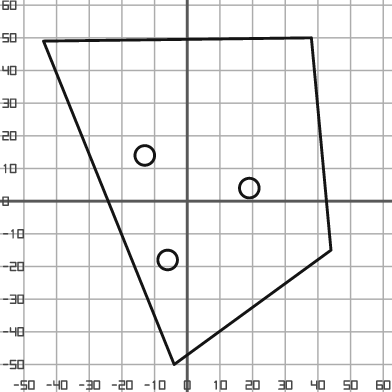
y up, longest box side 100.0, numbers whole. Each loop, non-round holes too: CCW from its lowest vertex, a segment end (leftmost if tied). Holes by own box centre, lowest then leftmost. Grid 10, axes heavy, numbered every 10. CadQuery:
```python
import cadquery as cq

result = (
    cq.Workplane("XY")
    .moveTo(-4.0, -50.0)
    .lineTo(44.0, -15.0)
    .lineTo(38.0, 50.0)
    .lineTo(-44.0, 49.0)
    .close()
    .moveTo(-6.0, -18.0)
    .circle(3.0)
    .moveTo(19.0, 4.0)
    .circle(3.0)
    .moveTo(-13.0, 14.0)
    .circle(3.0)
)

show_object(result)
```